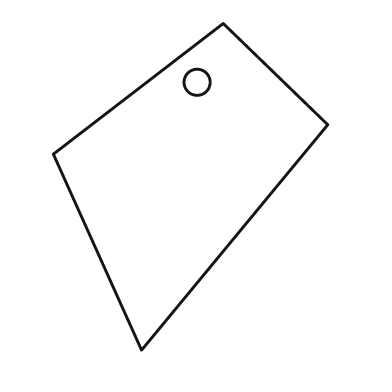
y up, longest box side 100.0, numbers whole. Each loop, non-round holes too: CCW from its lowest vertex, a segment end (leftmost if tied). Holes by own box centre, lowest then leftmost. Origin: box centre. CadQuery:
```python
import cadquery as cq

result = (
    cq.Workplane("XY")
    .moveTo(-15.0, -50.0)
    .lineTo(42.0, 19.0)
    .lineTo(10.0, 50.0)
    .lineTo(-42.0, 10.0)
    .close()
    .moveTo(2.0, 32.0)
    .circle(4.0)
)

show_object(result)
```